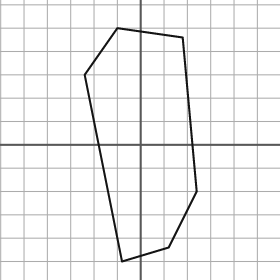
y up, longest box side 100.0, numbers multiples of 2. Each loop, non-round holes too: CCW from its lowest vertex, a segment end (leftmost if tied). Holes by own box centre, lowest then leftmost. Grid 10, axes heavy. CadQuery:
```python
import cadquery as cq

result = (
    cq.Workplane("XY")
    .moveTo(-8.0, -50.0)
    .lineTo(12.0, -44.0)
    .lineTo(24.0, -20.0)
    .lineTo(18.0, 46.0)
    .lineTo(-10.0, 50.0)
    .lineTo(-24.0, 30.0)
    .close()
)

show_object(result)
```